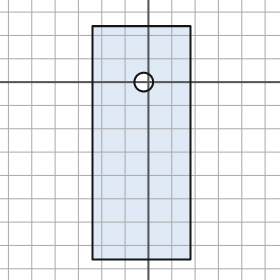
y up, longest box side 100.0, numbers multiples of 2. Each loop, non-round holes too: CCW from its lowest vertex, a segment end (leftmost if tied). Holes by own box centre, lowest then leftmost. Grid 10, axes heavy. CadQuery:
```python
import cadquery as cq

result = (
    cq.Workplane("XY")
    .moveTo(-24.0, -76.0)
    .lineTo(18.0, -76.0)
    .lineTo(18.0, 24.0)
    .lineTo(-24.0, 24.0)
    .close()
    .moveTo(-2.0, 0.0)
    .circle(4.0)
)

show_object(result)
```